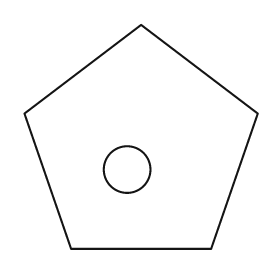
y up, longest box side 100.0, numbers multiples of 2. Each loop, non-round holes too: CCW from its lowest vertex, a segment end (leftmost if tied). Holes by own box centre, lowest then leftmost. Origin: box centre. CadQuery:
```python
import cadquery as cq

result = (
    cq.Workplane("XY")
    .moveTo(-30.0, -48.0)
    .lineTo(30.0, -48.0)
    .lineTo(50.0, 10.0)
    .lineTo(0.0, 48.0)
    .lineTo(-50.0, 10.0)
    .close()
    .moveTo(-6.0, -14.0)
    .circle(10.0)
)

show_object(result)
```